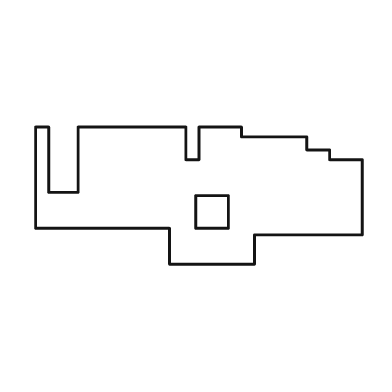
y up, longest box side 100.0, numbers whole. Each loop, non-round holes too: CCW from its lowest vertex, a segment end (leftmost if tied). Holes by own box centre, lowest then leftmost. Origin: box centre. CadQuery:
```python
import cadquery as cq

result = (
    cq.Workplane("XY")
    .moveTo(-9.0, -21.0)
    .lineTo(17.0, -21.0)
    .lineTo(17.0, -12.0)
    .lineTo(50.0, -12.0)
    .lineTo(50.0, 11.0)
    .lineTo(40.0, 11.0)
    .lineTo(40.0, 14.0)
    .lineTo(33.0, 14.0)
    .lineTo(33.0, 18.0)
    .lineTo(13.0, 18.0)
    .lineTo(13.0, 21.0)
    .lineTo(0.0, 21.0)
    .lineTo(0.0, 11.0)
    .lineTo(-4.0, 11.0)
    .lineTo(-4.0, 21.0)
    .lineTo(-37.0, 21.0)
    .lineTo(-37.0, 1.0)
    .lineTo(-46.0, 1.0)
    .lineTo(-46.0, 21.0)
    .lineTo(-50.0, 21.0)
    .lineTo(-50.0, -10.0)
    .lineTo(-9.0, -10.0)
    .close()
    .moveTo(-1.0, -10.0)
    .lineTo(9.0, -10.0)
    .lineTo(9.0, 0.0)
    .lineTo(-1.0, 0.0)
    .close()
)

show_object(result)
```